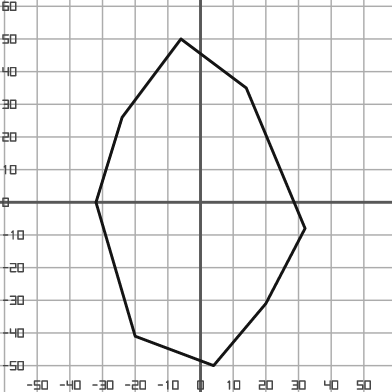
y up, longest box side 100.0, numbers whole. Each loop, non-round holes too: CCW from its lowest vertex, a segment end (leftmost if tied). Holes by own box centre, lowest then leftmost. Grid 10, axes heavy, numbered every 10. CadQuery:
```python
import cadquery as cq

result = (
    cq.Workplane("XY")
    .moveTo(4.0, -50.0)
    .lineTo(20.0, -31.0)
    .lineTo(32.0, -8.0)
    .lineTo(14.0, 35.0)
    .lineTo(-6.0, 50.0)
    .lineTo(-24.0, 26.0)
    .lineTo(-32.0, 0.0)
    .lineTo(-20.0, -41.0)
    .close()
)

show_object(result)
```